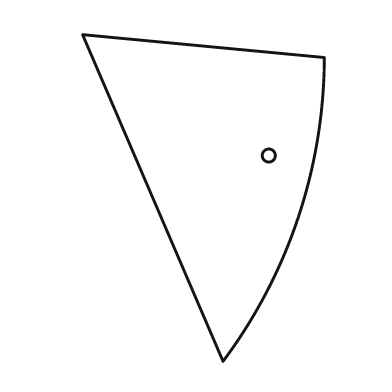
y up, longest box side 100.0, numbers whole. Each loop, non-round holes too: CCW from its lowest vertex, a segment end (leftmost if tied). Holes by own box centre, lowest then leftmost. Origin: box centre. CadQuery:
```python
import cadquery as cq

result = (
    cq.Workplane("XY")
    .moveTo(6.0, -50.0)
    .threePointArc((29.0, -6.0), (37.0, 43.0))
    .lineTo(-37.0, 50.0)
    .close()
    .moveTo(20.0, 13.0)
    .circle(2.0)
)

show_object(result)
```